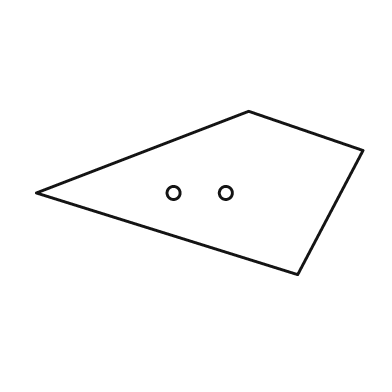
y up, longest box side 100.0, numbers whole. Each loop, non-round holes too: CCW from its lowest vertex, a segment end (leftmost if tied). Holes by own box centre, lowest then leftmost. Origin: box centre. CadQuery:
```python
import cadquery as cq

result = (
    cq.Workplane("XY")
    .moveTo(30.0, -25.0)
    .lineTo(50.0, 13.0)
    .lineTo(15.0, 25.0)
    .lineTo(-50.0, 0.0)
    .close()
    .moveTo(-8.0, 0.0)
    .circle(2.0)
    .moveTo(8.0, 0.0)
    .circle(2.0)
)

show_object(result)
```